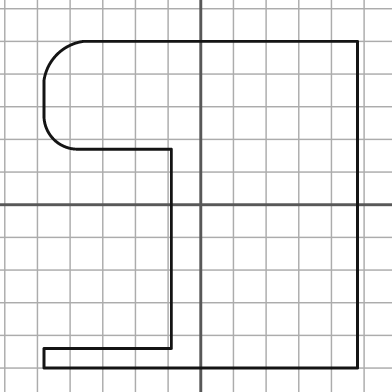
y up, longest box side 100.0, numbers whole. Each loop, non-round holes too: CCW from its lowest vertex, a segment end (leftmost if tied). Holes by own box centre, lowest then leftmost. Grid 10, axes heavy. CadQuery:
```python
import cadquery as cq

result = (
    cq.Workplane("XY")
    .moveTo(-48.0, -50.0)
    .lineTo(48.0, -50.0)
    .lineTo(48.0, 50.0)
    .lineTo(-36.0, 50.0)
    .threePointArc((-44.0, 46.0), (-48.0, 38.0))
    .lineTo(-48.0, 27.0)
    .threePointArc((-45.0, 20.0), (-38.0, 17.0))
    .lineTo(-9.0, 17.0)
    .lineTo(-9.0, -44.0)
    .lineTo(-48.0, -44.0)
    .close()
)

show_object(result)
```